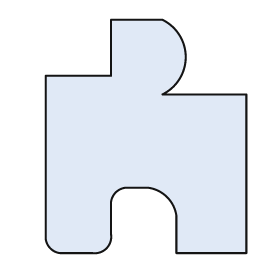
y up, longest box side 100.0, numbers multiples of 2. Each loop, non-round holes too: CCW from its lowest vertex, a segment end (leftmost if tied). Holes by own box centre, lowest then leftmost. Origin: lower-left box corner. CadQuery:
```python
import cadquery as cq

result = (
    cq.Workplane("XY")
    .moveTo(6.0, 0.0)
    .lineTo(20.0, 0.0)
    .threePointArc((26.0, 2.0), (28.0, 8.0))
    .lineTo(28.0, 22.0)
    .threePointArc((30.0, 26.0), (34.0, 28.0))
    .lineTo(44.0, 28.0)
    .threePointArc((52.0, 24.0), (56.0, 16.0))
    .lineTo(56.0, 0.0)
    .lineTo(86.0, 0.0)
    .lineTo(86.0, 68.0)
    .lineTo(50.0, 68.0)
    .threePointArc((60.0, 84.0), (50.0, 100.0))
    .lineTo(28.0, 100.0)
    .lineTo(28.0, 76.0)
    .lineTo(0.0, 76.0)
    .lineTo(0.0, 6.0)
    .threePointArc((2.0, 2.0), (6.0, 0.0))
    .close()
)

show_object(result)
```